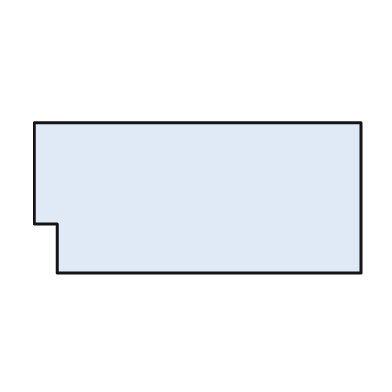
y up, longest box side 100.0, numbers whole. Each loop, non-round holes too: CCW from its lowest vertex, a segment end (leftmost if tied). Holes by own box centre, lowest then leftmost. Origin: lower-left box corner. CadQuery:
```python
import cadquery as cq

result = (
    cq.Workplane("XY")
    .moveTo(7.0, 0.0)
    .lineTo(100.0, 0.0)
    .lineTo(100.0, 46.0)
    .lineTo(0.0, 46.0)
    .lineTo(0.0, 15.0)
    .lineTo(7.0, 15.0)
    .close()
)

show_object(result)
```